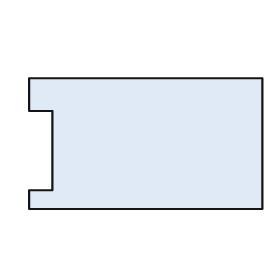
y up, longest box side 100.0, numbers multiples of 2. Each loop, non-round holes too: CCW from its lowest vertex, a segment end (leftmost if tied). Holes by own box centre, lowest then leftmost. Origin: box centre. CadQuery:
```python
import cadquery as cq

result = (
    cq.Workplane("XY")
    .moveTo(-50.0, -28.0)
    .lineTo(50.0, -28.0)
    .lineTo(50.0, 28.0)
    .lineTo(-50.0, 28.0)
    .lineTo(-50.0, 14.0)
    .lineTo(-40.0, 14.0)
    .lineTo(-40.0, -20.0)
    .lineTo(-50.0, -20.0)
    .close()
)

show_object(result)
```